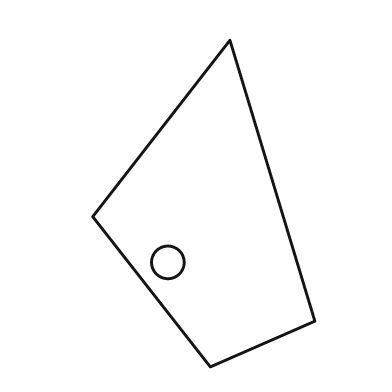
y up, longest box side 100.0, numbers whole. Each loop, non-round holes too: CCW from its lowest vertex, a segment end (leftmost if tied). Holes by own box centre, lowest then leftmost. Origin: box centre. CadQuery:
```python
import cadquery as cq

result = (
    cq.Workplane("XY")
    .moveTo(2.0, -50.0)
    .lineTo(34.0, -36.0)
    .lineTo(8.0, 50.0)
    .lineTo(-34.0, -4.0)
    .close()
    .moveTo(-11.0, -18.0)
    .circle(5.0)
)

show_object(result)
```